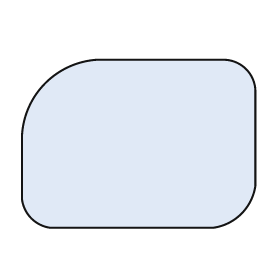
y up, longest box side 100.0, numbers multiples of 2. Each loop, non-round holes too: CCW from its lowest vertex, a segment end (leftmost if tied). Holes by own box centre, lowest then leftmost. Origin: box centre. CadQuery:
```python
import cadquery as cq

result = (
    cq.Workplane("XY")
    .moveTo(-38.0, -36.0)
    .lineTo(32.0, -36.0)
    .threePointArc((44.0, -30.0), (50.0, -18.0))
    .lineTo(50.0, 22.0)
    .threePointArc((46.0, 32.0), (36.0, 36.0))
    .lineTo(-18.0, 36.0)
    .threePointArc((-40.0, 26.0), (-50.0, 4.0))
    .lineTo(-50.0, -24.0)
    .threePointArc((-46.0, -32.0), (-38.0, -36.0))
    .close()
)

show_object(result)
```